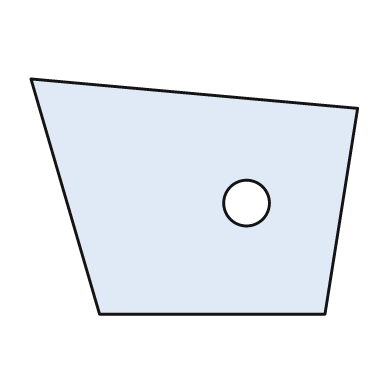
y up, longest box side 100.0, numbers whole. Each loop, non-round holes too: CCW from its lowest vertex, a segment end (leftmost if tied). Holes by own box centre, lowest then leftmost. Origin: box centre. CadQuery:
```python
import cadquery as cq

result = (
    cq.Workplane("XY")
    .moveTo(-29.0, -36.0)
    .lineTo(40.0, -36.0)
    .lineTo(50.0, 27.0)
    .lineTo(-50.0, 36.0)
    .close()
    .moveTo(16.0, -2.0)
    .circle(7.0)
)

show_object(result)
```